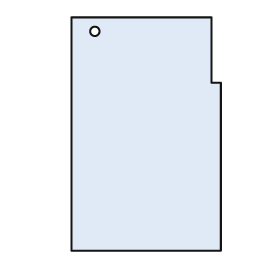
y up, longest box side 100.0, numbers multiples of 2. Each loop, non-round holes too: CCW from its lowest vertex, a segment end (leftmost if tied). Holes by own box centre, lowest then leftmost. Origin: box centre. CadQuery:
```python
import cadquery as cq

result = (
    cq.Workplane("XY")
    .moveTo(-32.0, -50.0)
    .lineTo(32.0, -50.0)
    .lineTo(32.0, 22.0)
    .lineTo(28.0, 22.0)
    .lineTo(28.0, 50.0)
    .lineTo(-32.0, 50.0)
    .close()
    .moveTo(-22.0, 44.0)
    .circle(2.0)
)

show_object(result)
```